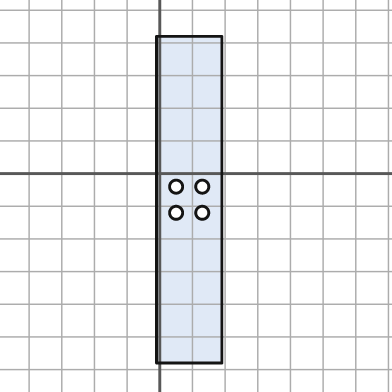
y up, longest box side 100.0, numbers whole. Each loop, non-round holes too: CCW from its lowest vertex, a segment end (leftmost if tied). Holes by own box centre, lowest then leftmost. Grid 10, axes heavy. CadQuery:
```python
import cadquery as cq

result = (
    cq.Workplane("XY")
    .moveTo(-1.0, -58.0)
    .lineTo(19.0, -58.0)
    .lineTo(19.0, 42.0)
    .lineTo(-1.0, 42.0)
    .close()
    .moveTo(5.0, -12.0)
    .circle(2.0)
    .moveTo(13.0, -12.0)
    .circle(2.0)
    .moveTo(5.0, -4.0)
    .circle(2.0)
    .moveTo(13.0, -4.0)
    .circle(2.0)
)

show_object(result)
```